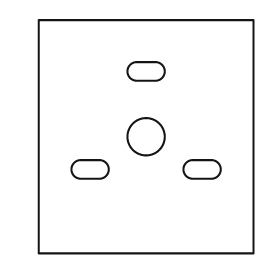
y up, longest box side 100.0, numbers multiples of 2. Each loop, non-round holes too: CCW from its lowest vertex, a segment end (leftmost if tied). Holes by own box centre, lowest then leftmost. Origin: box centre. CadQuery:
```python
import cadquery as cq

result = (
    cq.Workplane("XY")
    .moveTo(-46.0, -50.0)
    .lineTo(46.0, -50.0)
    .lineTo(46.0, 50.0)
    .lineTo(-46.0, 50.0)
    .close()
    .moveTo(-28.0, -18.0)
    .lineTo(-20.0, -18.0)
    .threePointArc((-16.0, -14.0), (-20.0, -10.0))
    .lineTo(-28.0, -10.0)
    .threePointArc((-32.0, -14.0), (-28.0, -18.0))
    .close()
    .moveTo(20.0, -18.0)
    .lineTo(28.0, -18.0)
    .threePointArc((32.0, -14.0), (28.0, -10.0))
    .lineTo(20.0, -10.0)
    .threePointArc((16.0, -14.0), (20.0, -18.0))
    .close()
    .moveTo(0.0, 0.0)
    .circle(8.0)
    .moveTo(-4.0, 24.0)
    .lineTo(4.0, 24.0)
    .threePointArc((8.0, 28.0), (4.0, 32.0))
    .lineTo(-4.0, 32.0)
    .threePointArc((-8.0, 28.0), (-4.0, 24.0))
    .close()
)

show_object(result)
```